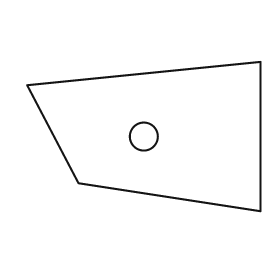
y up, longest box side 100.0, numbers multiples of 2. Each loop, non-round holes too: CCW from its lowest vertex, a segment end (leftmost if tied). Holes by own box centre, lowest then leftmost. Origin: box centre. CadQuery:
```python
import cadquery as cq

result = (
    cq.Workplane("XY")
    .moveTo(50.0, -32.0)
    .lineTo(50.0, 32.0)
    .lineTo(-50.0, 22.0)
    .lineTo(-28.0, -20.0)
    .close()
    .moveTo(0.0, 0.0)
    .circle(6.0)
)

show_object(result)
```